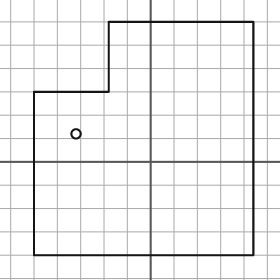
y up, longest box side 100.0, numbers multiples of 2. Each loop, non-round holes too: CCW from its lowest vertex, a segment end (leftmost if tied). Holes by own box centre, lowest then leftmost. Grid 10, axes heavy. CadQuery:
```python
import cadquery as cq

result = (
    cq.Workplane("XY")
    .moveTo(-50.0, -40.0)
    .lineTo(44.0, -40.0)
    .lineTo(44.0, 60.0)
    .lineTo(-18.0, 60.0)
    .lineTo(-18.0, 30.0)
    .lineTo(-50.0, 30.0)
    .close()
    .moveTo(-32.0, 12.0)
    .circle(2.0)
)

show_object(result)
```